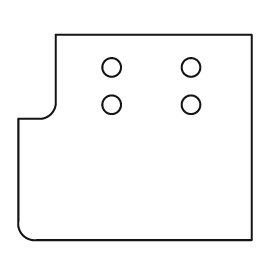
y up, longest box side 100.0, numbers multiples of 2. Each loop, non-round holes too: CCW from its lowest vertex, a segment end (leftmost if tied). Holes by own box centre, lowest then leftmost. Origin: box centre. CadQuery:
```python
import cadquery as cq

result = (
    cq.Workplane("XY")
    .moveTo(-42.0, -44.0)
    .lineTo(50.0, -44.0)
    .lineTo(50.0, 44.0)
    .lineTo(-34.0, 44.0)
    .lineTo(-34.0, 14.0)
    .threePointArc((-36.0, 10.0), (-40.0, 8.0))
    .lineTo(-50.0, 8.0)
    .lineTo(-50.0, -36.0)
    .threePointArc((-48.0, -42.0), (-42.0, -44.0))
    .close()
    .moveTo(-10.0, 14.0)
    .circle(4.0)
    .moveTo(24.0, 14.0)
    .circle(4.0)
    .moveTo(-10.0, 30.0)
    .circle(4.0)
    .moveTo(24.0, 30.0)
    .circle(4.0)
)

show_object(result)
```